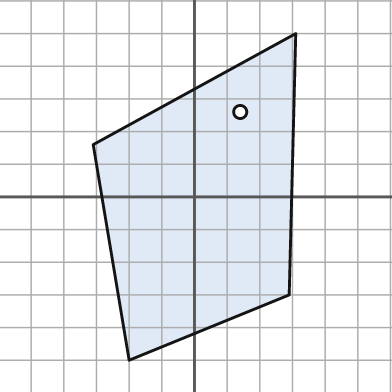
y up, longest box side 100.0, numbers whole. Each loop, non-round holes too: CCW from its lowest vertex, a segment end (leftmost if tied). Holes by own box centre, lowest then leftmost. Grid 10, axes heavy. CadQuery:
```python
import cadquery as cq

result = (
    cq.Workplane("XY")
    .moveTo(-20.0, -50.0)
    .lineTo(29.0, -30.0)
    .lineTo(31.0, 50.0)
    .lineTo(-31.0, 16.0)
    .close()
    .moveTo(14.0, 26.0)
    .circle(2.0)
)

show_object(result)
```